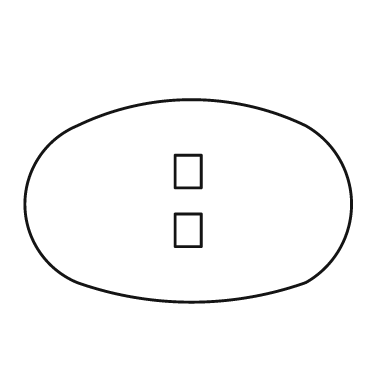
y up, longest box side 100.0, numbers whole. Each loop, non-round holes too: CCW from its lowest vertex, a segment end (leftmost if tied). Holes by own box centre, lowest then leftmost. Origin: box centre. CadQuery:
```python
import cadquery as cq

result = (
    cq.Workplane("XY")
    .moveTo(-34.0, -25.0)
    .threePointArc((1.0, -31.0), (36.0, -25.0))
    .threePointArc((50.0, -1.0), (36.0, 23.0))
    .threePointArc((1.0, 31.0), (-34.0, 23.0))
    .threePointArc((-50.0, -1.0), (-34.0, -25.0))
    .close()
    .moveTo(-4.0, -14.0)
    .lineTo(4.0, -14.0)
    .lineTo(4.0, -4.0)
    .lineTo(-4.0, -4.0)
    .close()
    .moveTo(-4.0, 4.0)
    .lineTo(4.0, 4.0)
    .lineTo(4.0, 14.0)
    .lineTo(-4.0, 14.0)
    .close()
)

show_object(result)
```